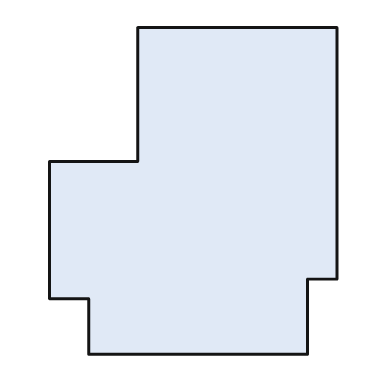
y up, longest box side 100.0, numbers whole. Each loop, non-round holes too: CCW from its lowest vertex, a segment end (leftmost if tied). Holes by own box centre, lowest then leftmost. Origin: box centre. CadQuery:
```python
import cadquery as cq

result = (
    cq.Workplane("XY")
    .moveTo(-32.0, -50.0)
    .lineTo(35.0, -50.0)
    .lineTo(35.0, -27.0)
    .lineTo(44.0, -27.0)
    .lineTo(44.0, 50.0)
    .lineTo(-17.0, 50.0)
    .lineTo(-17.0, 9.0)
    .lineTo(-44.0, 9.0)
    .lineTo(-44.0, -33.0)
    .lineTo(-32.0, -33.0)
    .close()
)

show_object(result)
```